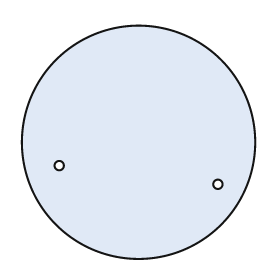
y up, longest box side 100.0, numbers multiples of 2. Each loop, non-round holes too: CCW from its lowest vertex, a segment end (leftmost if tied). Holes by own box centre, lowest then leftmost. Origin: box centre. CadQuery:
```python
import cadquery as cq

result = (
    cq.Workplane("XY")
    .moveTo(0.0, 0.0)
    .circle(50.0)
    .moveTo(34.0, -18.0)
    .circle(2.0)
    .moveTo(-34.0, -10.0)
    .circle(2.0)
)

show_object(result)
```